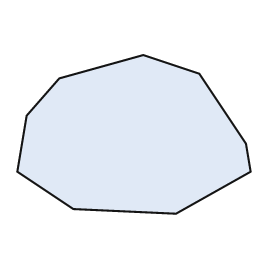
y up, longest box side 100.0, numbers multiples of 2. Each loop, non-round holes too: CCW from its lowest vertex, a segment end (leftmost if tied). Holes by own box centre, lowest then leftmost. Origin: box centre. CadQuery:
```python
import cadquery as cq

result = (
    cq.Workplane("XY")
    .moveTo(18.0, -34.0)
    .lineTo(50.0, -16.0)
    .lineTo(48.0, -4.0)
    .lineTo(28.0, 26.0)
    .lineTo(4.0, 34.0)
    .lineTo(-32.0, 24.0)
    .lineTo(-46.0, 8.0)
    .lineTo(-50.0, -16.0)
    .lineTo(-26.0, -32.0)
    .close()
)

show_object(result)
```